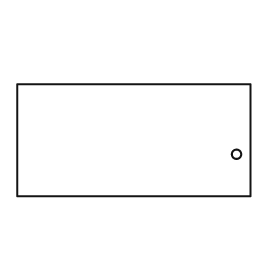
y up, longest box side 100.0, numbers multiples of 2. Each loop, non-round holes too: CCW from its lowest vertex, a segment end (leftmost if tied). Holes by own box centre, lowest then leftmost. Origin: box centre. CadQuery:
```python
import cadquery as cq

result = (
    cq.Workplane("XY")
    .moveTo(-50.0, -24.0)
    .lineTo(50.0, -24.0)
    .lineTo(50.0, 24.0)
    .lineTo(-50.0, 24.0)
    .close()
    .moveTo(44.0, -6.0)
    .circle(2.0)
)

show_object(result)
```